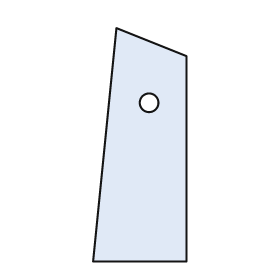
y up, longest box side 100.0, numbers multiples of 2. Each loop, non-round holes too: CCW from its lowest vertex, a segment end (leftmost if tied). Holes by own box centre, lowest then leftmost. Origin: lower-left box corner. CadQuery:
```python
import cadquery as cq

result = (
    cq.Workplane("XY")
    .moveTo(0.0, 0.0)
    .lineTo(40.0, 0.0)
    .lineTo(40.0, 88.0)
    .lineTo(10.0, 100.0)
    .close()
    .moveTo(24.0, 68.0)
    .circle(4.0)
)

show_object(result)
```